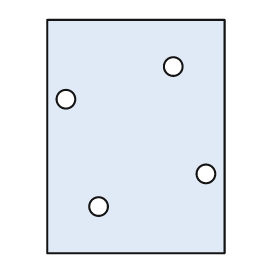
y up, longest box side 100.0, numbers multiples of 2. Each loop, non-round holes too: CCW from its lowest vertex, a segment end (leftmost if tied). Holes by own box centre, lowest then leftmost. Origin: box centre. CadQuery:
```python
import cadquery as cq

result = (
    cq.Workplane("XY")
    .moveTo(-38.0, -50.0)
    .lineTo(38.0, -50.0)
    .lineTo(38.0, 50.0)
    .lineTo(-38.0, 50.0)
    .close()
    .moveTo(-16.0, -30.0)
    .circle(4.0)
    .moveTo(30.0, -16.0)
    .circle(4.0)
    .moveTo(-30.0, 16.0)
    .circle(4.0)
    .moveTo(16.0, 30.0)
    .circle(4.0)
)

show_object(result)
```